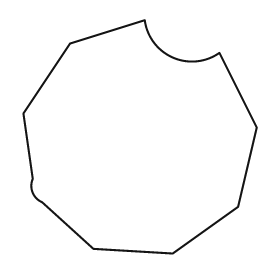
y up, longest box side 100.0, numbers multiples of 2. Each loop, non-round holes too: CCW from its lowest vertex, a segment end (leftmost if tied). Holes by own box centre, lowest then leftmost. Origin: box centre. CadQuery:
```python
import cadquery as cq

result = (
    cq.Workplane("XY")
    .moveTo(14.0, -50.0)
    .lineTo(42.0, -30.0)
    .lineTo(50.0, 4.0)
    .lineTo(34.0, 36.0)
    .threePointArc((14.0, 34.0), (2.0, 50.0))
    .lineTo(-30.0, 40.0)
    .lineTo(-50.0, 10.0)
    .lineTo(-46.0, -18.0)
    .threePointArc((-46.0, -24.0), (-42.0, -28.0))
    .lineTo(-20.0, -48.0)
    .close()
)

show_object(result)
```